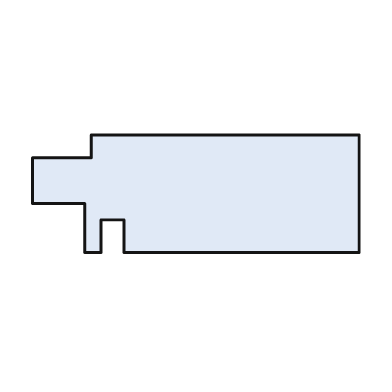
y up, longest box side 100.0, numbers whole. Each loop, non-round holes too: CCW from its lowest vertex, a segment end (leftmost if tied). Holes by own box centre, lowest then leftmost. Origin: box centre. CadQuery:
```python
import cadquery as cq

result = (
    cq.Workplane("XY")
    .moveTo(-34.0, -18.0)
    .lineTo(-29.0, -18.0)
    .lineTo(-29.0, -8.0)
    .lineTo(-22.0, -8.0)
    .lineTo(-22.0, -18.0)
    .lineTo(50.0, -18.0)
    .lineTo(50.0, 18.0)
    .lineTo(-32.0, 18.0)
    .lineTo(-32.0, 11.0)
    .lineTo(-50.0, 11.0)
    .lineTo(-50.0, -3.0)
    .lineTo(-34.0, -3.0)
    .close()
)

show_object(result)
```